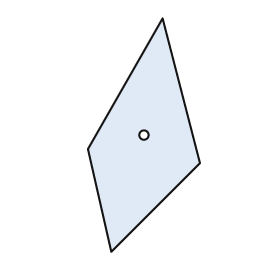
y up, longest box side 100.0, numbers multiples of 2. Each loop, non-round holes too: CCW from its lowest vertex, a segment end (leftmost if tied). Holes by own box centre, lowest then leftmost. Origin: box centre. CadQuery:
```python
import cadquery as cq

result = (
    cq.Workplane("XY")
    .moveTo(-14.0, -50.0)
    .lineTo(24.0, -12.0)
    .lineTo(8.0, 50.0)
    .lineTo(-24.0, -6.0)
    .close()
    .moveTo(0.0, 0.0)
    .circle(2.0)
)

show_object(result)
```